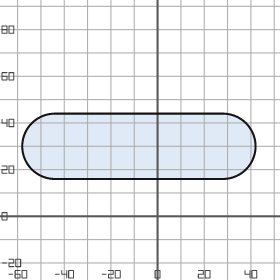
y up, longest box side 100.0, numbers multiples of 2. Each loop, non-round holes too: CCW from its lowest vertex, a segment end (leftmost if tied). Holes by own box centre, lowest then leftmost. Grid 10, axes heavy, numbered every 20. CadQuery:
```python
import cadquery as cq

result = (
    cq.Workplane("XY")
    .moveTo(-44.0, 16.0)
    .lineTo(28.0, 16.0)
    .threePointArc((42.0, 30.0), (28.0, 44.0))
    .lineTo(-44.0, 44.0)
    .threePointArc((-58.0, 30.0), (-44.0, 16.0))
    .close()
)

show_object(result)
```